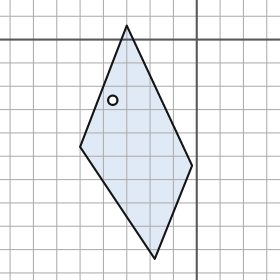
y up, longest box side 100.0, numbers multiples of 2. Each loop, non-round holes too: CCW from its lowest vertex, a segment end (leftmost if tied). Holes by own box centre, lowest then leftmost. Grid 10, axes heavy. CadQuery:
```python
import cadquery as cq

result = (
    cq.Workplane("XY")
    .moveTo(-18.0, -94.0)
    .lineTo(-2.0, -54.0)
    .lineTo(-30.0, 6.0)
    .lineTo(-50.0, -46.0)
    .close()
    .moveTo(-36.0, -26.0)
    .circle(2.0)
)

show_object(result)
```